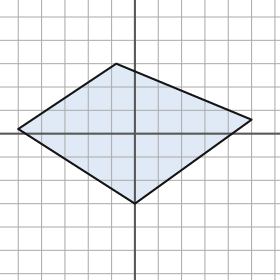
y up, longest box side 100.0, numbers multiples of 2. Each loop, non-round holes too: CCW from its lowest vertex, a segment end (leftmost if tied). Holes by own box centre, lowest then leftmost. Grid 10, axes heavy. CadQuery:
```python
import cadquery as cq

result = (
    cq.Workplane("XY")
    .moveTo(0.0, -30.0)
    .lineTo(50.0, 6.0)
    .lineTo(-8.0, 30.0)
    .lineTo(-50.0, 2.0)
    .close()
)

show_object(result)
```